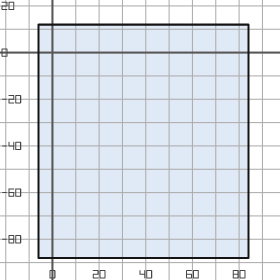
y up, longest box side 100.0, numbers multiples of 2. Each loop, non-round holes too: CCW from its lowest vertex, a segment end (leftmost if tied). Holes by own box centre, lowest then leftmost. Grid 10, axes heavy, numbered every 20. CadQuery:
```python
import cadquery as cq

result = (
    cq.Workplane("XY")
    .moveTo(-6.0, -88.0)
    .lineTo(84.0, -88.0)
    .lineTo(84.0, 12.0)
    .lineTo(-6.0, 12.0)
    .close()
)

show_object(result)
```